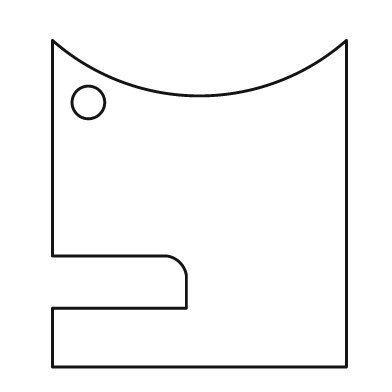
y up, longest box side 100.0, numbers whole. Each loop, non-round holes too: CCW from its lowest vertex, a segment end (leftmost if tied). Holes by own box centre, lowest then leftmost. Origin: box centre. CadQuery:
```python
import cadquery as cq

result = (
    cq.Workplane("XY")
    .moveTo(-45.0, -50.0)
    .lineTo(45.0, -50.0)
    .lineTo(45.0, 50.0)
    .threePointArc((0.0, 33.0), (-45.0, 50.0))
    .lineTo(-45.0, -16.0)
    .lineTo(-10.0, -16.0)
    .threePointArc((-6.0, -18.0), (-4.0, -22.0))
    .lineTo(-4.0, -32.0)
    .lineTo(-45.0, -32.0)
    .close()
    .moveTo(-34.0, 31.0)
    .circle(5.0)
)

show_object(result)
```